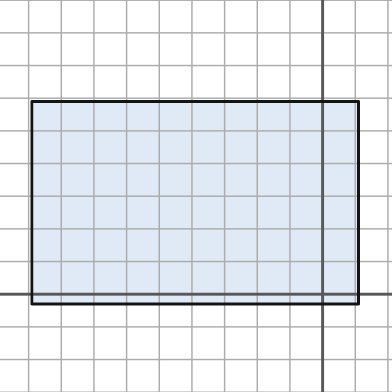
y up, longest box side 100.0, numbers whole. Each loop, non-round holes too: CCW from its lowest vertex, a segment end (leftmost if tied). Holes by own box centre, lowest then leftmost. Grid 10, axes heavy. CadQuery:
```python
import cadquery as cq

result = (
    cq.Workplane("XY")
    .moveTo(-89.0, -3.0)
    .lineTo(11.0, -3.0)
    .lineTo(11.0, 59.0)
    .lineTo(-89.0, 59.0)
    .close()
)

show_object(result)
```